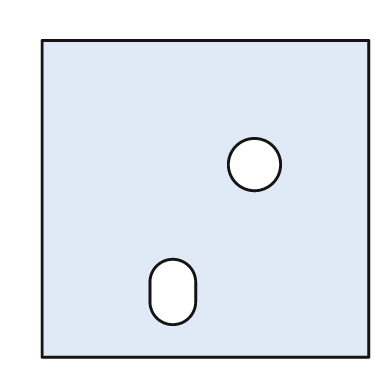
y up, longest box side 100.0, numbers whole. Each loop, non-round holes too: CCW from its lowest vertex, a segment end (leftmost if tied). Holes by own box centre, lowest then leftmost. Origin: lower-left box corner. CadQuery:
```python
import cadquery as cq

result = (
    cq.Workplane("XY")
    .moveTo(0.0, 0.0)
    .lineTo(100.0, 0.0)
    .lineTo(100.0, 97.0)
    .lineTo(0.0, 97.0)
    .close()
    .moveTo(33.0, 17.0)
    .threePointArc((40.0, 10.0), (47.0, 17.0))
    .lineTo(47.0, 23.0)
    .threePointArc((40.0, 30.0), (33.0, 23.0))
    .close()
    .moveTo(65.0, 59.0)
    .circle(8.0)
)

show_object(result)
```